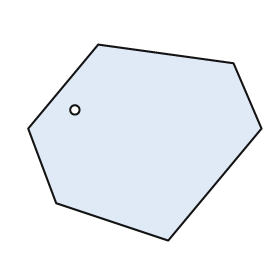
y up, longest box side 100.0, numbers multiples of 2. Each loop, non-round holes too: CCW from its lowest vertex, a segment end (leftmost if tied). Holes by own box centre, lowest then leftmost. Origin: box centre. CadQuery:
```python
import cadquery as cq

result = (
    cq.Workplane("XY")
    .moveTo(10.0, -42.0)
    .lineTo(50.0, 6.0)
    .lineTo(38.0, 34.0)
    .lineTo(-20.0, 42.0)
    .lineTo(-50.0, 6.0)
    .lineTo(-38.0, -26.0)
    .close()
    .moveTo(-30.0, 14.0)
    .circle(2.0)
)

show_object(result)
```